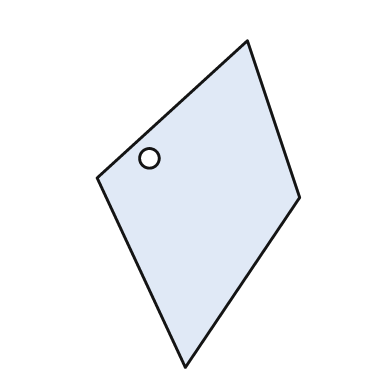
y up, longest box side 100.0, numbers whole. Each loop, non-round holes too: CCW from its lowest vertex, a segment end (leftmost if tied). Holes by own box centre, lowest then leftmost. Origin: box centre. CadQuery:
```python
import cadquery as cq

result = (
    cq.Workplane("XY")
    .moveTo(-4.0, -50.0)
    .lineTo(31.0, 2.0)
    .lineTo(15.0, 50.0)
    .lineTo(-31.0, 8.0)
    .close()
    .moveTo(-15.0, 14.0)
    .circle(3.0)
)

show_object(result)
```